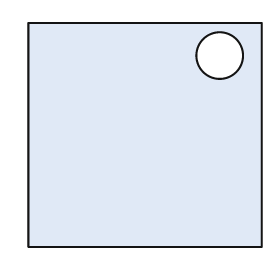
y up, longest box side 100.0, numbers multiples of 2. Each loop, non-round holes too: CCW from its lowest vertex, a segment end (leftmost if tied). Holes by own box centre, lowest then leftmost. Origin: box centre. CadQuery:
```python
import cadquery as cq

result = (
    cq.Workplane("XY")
    .moveTo(-50.0, -48.0)
    .lineTo(50.0, -48.0)
    .lineTo(50.0, 48.0)
    .lineTo(-50.0, 48.0)
    .close()
    .moveTo(32.0, 34.0)
    .circle(10.0)
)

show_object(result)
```